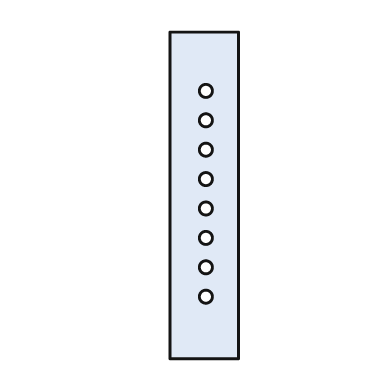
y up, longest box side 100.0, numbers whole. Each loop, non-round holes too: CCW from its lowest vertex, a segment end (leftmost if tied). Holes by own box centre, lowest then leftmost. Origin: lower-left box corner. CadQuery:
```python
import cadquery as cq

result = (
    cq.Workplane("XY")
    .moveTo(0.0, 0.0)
    .lineTo(21.0, 0.0)
    .lineTo(21.0, 100.0)
    .lineTo(0.0, 100.0)
    .close()
    .moveTo(11.0, 19.0)
    .circle(2.0)
    .moveTo(11.0, 28.0)
    .circle(2.0)
    .moveTo(11.0, 37.0)
    .circle(2.0)
    .moveTo(11.0, 46.0)
    .circle(2.0)
    .moveTo(11.0, 55.0)
    .circle(2.0)
    .moveTo(11.0, 64.0)
    .circle(2.0)
    .moveTo(11.0, 73.0)
    .circle(2.0)
    .moveTo(11.0, 82.0)
    .circle(2.0)
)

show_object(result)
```